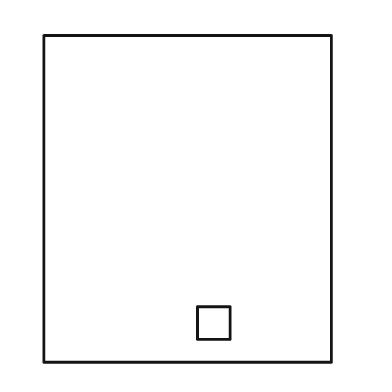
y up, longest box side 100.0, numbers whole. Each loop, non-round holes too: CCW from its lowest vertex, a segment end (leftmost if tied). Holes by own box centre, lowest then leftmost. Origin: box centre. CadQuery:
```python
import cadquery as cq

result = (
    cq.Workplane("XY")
    .moveTo(-44.0, -50.0)
    .lineTo(44.0, -50.0)
    .lineTo(44.0, 50.0)
    .lineTo(-44.0, 50.0)
    .close()
    .moveTo(3.0, -43.0)
    .lineTo(13.0, -43.0)
    .lineTo(13.0, -33.0)
    .lineTo(3.0, -33.0)
    .close()
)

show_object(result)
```